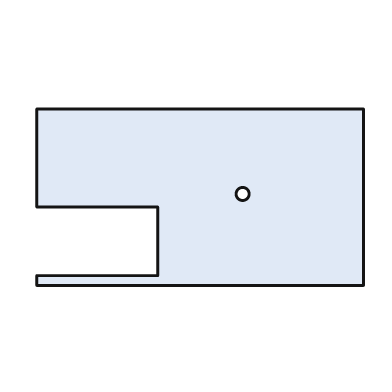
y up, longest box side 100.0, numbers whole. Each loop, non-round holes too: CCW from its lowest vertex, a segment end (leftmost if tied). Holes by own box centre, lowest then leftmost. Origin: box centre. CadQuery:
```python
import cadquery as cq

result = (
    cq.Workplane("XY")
    .moveTo(-50.0, -27.0)
    .lineTo(50.0, -27.0)
    .lineTo(50.0, 27.0)
    .lineTo(-50.0, 27.0)
    .lineTo(-50.0, -3.0)
    .lineTo(-13.0, -3.0)
    .lineTo(-13.0, -24.0)
    .lineTo(-50.0, -24.0)
    .close()
    .moveTo(13.0, 1.0)
    .circle(2.0)
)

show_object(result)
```